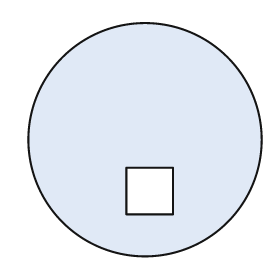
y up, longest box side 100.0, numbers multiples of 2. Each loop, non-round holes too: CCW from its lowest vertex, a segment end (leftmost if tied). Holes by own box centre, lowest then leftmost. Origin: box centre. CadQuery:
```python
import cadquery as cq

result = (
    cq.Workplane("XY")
    .moveTo(0.0, 0.0)
    .circle(50.0)
    .moveTo(-8.0, -32.0)
    .lineTo(12.0, -32.0)
    .lineTo(12.0, -12.0)
    .lineTo(-8.0, -12.0)
    .close()
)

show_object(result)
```